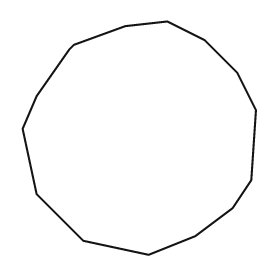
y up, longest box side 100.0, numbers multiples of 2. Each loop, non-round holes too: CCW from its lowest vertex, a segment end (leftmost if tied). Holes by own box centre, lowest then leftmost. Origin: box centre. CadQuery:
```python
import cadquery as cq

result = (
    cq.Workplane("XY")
    .moveTo(4.0, -50.0)
    .lineTo(24.0, -42.0)
    .lineTo(40.0, -30.0)
    .lineTo(48.0, -18.0)
    .lineTo(50.0, 12.0)
    .lineTo(42.0, 28.0)
    .lineTo(28.0, 42.0)
    .lineTo(12.0, 50.0)
    .lineTo(-6.0, 48.0)
    .lineTo(-28.0, 40.0)
    .lineTo(-30.0, 38.0)
    .lineTo(-44.0, 18.0)
    .lineTo(-50.0, 4.0)
    .lineTo(-44.0, -24.0)
    .lineTo(-24.0, -44.0)
    .close()
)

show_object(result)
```